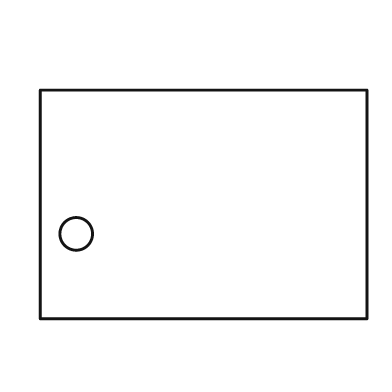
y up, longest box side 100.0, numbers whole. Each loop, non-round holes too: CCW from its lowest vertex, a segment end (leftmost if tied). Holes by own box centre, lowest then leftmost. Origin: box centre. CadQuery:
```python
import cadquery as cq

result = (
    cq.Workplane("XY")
    .moveTo(-50.0, -35.0)
    .lineTo(50.0, -35.0)
    .lineTo(50.0, 35.0)
    .lineTo(-50.0, 35.0)
    .close()
    .moveTo(-39.0, -9.0)
    .circle(5.0)
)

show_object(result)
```